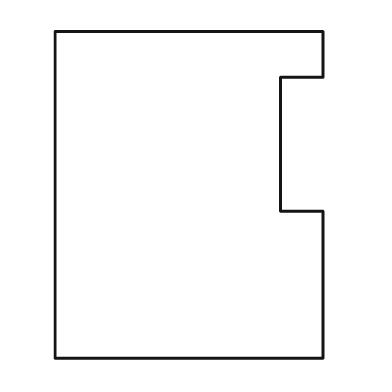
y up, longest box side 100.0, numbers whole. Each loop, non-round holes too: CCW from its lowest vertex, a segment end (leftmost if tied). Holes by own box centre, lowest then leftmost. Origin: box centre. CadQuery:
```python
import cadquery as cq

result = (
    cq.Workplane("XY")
    .moveTo(-41.0, -50.0)
    .lineTo(41.0, -50.0)
    .lineTo(41.0, -5.0)
    .lineTo(28.0, -5.0)
    .lineTo(28.0, 36.0)
    .lineTo(41.0, 36.0)
    .lineTo(41.0, 50.0)
    .lineTo(-41.0, 50.0)
    .close()
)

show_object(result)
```